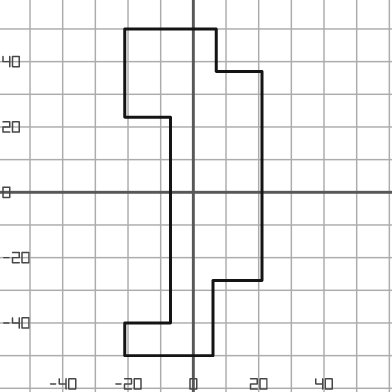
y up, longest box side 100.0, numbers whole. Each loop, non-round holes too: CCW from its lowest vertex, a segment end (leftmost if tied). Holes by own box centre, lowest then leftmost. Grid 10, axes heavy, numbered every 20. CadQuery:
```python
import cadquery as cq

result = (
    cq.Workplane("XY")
    .moveTo(-21.0, -50.0)
    .lineTo(6.0, -50.0)
    .lineTo(6.0, -27.0)
    .lineTo(21.0, -27.0)
    .lineTo(21.0, 37.0)
    .lineTo(7.0, 37.0)
    .lineTo(7.0, 50.0)
    .lineTo(-21.0, 50.0)
    .lineTo(-21.0, 23.0)
    .lineTo(-7.0, 23.0)
    .lineTo(-7.0, -40.0)
    .lineTo(-21.0, -40.0)
    .close()
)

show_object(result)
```